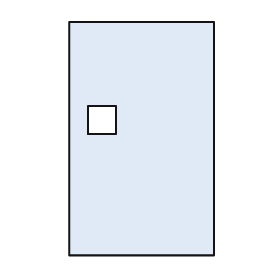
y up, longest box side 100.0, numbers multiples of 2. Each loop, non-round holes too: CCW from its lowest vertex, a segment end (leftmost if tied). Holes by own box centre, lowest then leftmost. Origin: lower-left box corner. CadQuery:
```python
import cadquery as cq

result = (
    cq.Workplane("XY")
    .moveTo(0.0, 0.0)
    .lineTo(62.0, 0.0)
    .lineTo(62.0, 100.0)
    .lineTo(0.0, 100.0)
    .close()
    .moveTo(8.0, 52.0)
    .lineTo(20.0, 52.0)
    .lineTo(20.0, 64.0)
    .lineTo(8.0, 64.0)
    .close()
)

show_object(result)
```